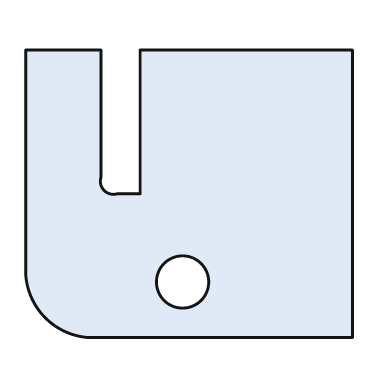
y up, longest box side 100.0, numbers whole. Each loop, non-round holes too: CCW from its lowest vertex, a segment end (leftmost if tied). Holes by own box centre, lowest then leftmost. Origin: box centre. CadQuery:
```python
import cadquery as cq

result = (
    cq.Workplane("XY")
    .moveTo(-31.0, -44.0)
    .lineTo(50.0, -44.0)
    .lineTo(50.0, 44.0)
    .lineTo(-15.0, 44.0)
    .lineTo(-15.0, 0.0)
    .lineTo(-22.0, 0.0)
    .threePointArc((-26.0, 1.0), (-27.0, 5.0))
    .lineTo(-27.0, 44.0)
    .lineTo(-50.0, 44.0)
    .lineTo(-50.0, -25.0)
    .threePointArc((-44.0, -38.0), (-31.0, -44.0))
    .close()
    .moveTo(-2.0, -27.0)
    .circle(8.0)
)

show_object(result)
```